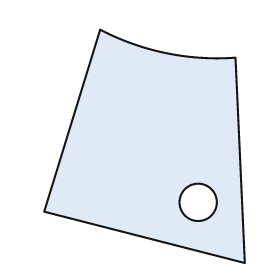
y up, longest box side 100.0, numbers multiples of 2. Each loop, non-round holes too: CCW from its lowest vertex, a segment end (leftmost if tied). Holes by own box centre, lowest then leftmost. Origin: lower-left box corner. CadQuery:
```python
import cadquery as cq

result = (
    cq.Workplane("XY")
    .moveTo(86.0, 0.0)
    .lineTo(82.0, 88.0)
    .threePointArc((52.0, 90.0), (24.0, 100.0))
    .lineTo(0.0, 22.0)
    .close()
    .moveTo(66.0, 26.0)
    .circle(8.0)
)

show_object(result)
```